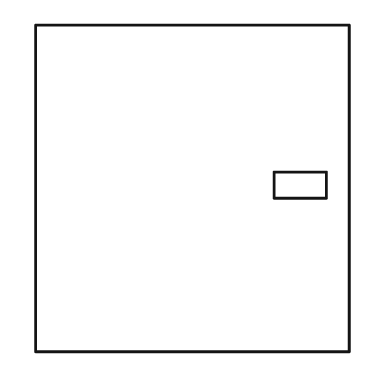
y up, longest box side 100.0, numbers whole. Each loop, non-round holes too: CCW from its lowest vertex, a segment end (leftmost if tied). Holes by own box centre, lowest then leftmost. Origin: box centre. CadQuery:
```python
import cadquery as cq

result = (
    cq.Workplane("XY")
    .moveTo(-48.0, -50.0)
    .lineTo(48.0, -50.0)
    .lineTo(48.0, 50.0)
    .lineTo(-48.0, 50.0)
    .close()
    .moveTo(25.0, -3.0)
    .lineTo(41.0, -3.0)
    .lineTo(41.0, 5.0)
    .lineTo(25.0, 5.0)
    .close()
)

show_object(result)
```